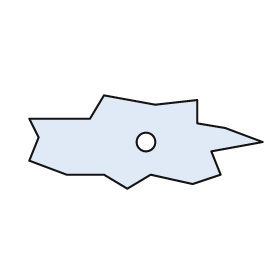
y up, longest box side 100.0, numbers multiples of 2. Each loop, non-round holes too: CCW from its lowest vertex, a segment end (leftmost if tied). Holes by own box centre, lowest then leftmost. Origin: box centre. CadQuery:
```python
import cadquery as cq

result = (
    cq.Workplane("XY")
    .moveTo(-8.0, -20.0)
    .lineTo(2.0, -14.0)
    .lineTo(20.0, -18.0)
    .lineTo(32.0, -14.0)
    .lineTo(28.0, -4.0)
    .lineTo(50.0, 0.0)
    .lineTo(34.0, 6.0)
    .lineTo(22.0, 8.0)
    .lineTo(22.0, 18.0)
    .lineTo(4.0, 16.0)
    .lineTo(-18.0, 20.0)
    .lineTo(-24.0, 10.0)
    .lineTo(-50.0, 10.0)
    .lineTo(-46.0, 2.0)
    .lineTo(-50.0, -8.0)
    .lineTo(-34.0, -14.0)
    .lineTo(-18.0, -14.0)
    .close()
    .moveTo(0.0, 0.0)
    .circle(4.0)
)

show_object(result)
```